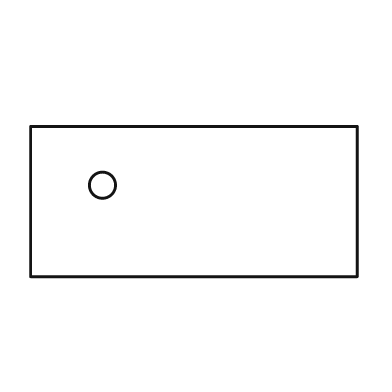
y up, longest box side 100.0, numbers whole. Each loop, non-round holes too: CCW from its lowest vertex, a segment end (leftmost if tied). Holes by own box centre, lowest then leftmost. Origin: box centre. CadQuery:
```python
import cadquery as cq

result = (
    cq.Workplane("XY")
    .moveTo(-50.0, -23.0)
    .lineTo(50.0, -23.0)
    .lineTo(50.0, 23.0)
    .lineTo(-50.0, 23.0)
    .close()
    .moveTo(-28.0, 5.0)
    .circle(4.0)
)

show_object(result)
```